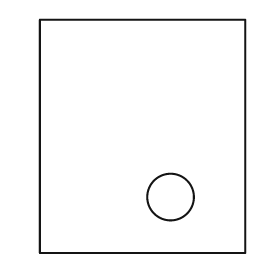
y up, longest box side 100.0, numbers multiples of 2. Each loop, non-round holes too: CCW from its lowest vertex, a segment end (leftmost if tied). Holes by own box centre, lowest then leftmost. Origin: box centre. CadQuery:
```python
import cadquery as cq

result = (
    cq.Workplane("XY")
    .moveTo(-44.0, -50.0)
    .lineTo(44.0, -50.0)
    .lineTo(44.0, 50.0)
    .lineTo(-44.0, 50.0)
    .close()
    .moveTo(12.0, -26.0)
    .circle(10.0)
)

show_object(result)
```